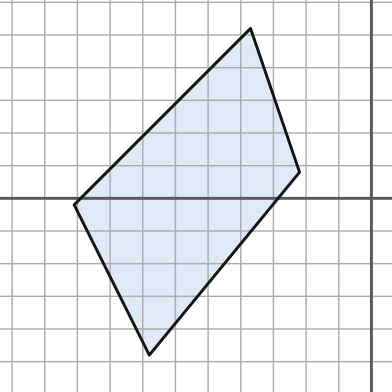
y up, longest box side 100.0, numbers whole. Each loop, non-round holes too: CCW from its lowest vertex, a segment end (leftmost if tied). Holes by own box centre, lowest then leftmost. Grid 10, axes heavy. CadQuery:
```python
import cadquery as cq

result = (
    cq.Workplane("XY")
    .moveTo(-68.0, -48.0)
    .lineTo(-22.0, 8.0)
    .lineTo(-37.0, 52.0)
    .lineTo(-91.0, -2.0)
    .close()
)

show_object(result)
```